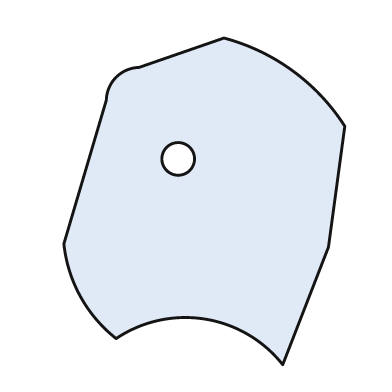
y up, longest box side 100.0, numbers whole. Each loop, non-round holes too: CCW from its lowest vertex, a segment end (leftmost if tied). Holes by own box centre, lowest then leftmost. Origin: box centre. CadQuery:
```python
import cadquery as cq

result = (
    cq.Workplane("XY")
    .moveTo(24.0, -50.0)
    .lineTo(38.0, -14.0)
    .lineTo(43.0, 23.0)
    .threePointArc((27.0, 40.0), (6.0, 50.0))
    .lineTo(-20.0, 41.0)
    .threePointArc((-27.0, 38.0), (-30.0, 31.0))
    .lineTo(-43.0, -13.0)
    .threePointArc((-38.0, -29.0), (-27.0, -42.0))
    .threePointArc((0.0, -36.0), (24.0, -50.0))
    .close()
    .moveTo(-8.0, 13.0)
    .circle(5.0)
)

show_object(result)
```